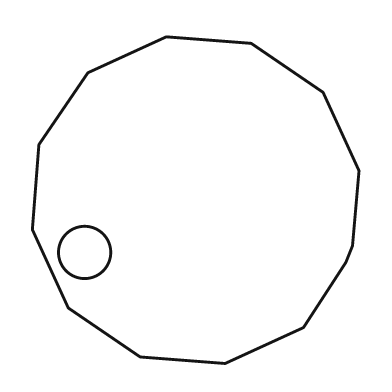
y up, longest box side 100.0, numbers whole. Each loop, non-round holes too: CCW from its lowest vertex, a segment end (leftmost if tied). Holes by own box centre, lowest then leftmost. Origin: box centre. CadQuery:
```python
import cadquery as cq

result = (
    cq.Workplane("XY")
    .moveTo(9.0, -50.0)
    .lineTo(33.0, -39.0)
    .lineTo(46.0, -19.0)
    .lineTo(48.0, -14.0)
    .lineTo(50.0, 9.0)
    .lineTo(39.0, 33.0)
    .lineTo(17.0, 48.0)
    .lineTo(-9.0, 50.0)
    .lineTo(-33.0, 39.0)
    .lineTo(-48.0, 17.0)
    .lineTo(-50.0, -9.0)
    .lineTo(-39.0, -33.0)
    .lineTo(-17.0, -48.0)
    .close()
    .moveTo(-34.0, -16.0)
    .circle(8.0)
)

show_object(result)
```